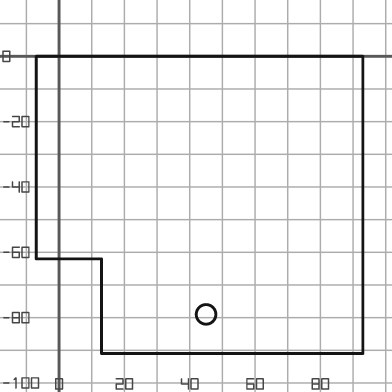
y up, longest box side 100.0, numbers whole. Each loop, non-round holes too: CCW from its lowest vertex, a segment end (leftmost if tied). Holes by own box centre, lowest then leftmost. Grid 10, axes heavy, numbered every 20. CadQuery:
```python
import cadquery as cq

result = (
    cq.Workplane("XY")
    .moveTo(13.0, -91.0)
    .lineTo(93.0, -91.0)
    .lineTo(93.0, 0.0)
    .lineTo(-7.0, 0.0)
    .lineTo(-7.0, -62.0)
    .lineTo(13.0, -62.0)
    .close()
    .moveTo(45.0, -79.0)
    .circle(3.0)
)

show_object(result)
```